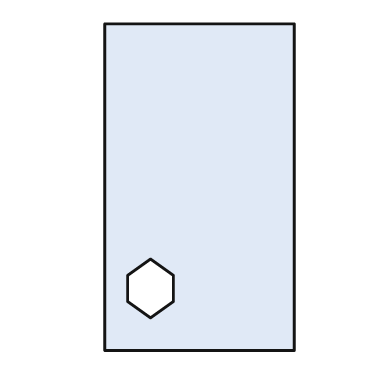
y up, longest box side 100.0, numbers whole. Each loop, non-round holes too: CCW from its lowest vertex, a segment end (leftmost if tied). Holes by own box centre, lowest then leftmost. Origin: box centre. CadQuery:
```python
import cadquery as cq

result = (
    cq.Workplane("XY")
    .moveTo(-29.0, -50.0)
    .lineTo(29.0, -50.0)
    .lineTo(29.0, 50.0)
    .lineTo(-29.0, 50.0)
    .close()
    .moveTo(-15.0, -40.0)
    .lineTo(-8.0, -35.0)
    .lineTo(-8.0, -27.0)
    .lineTo(-15.0, -22.0)
    .lineTo(-22.0, -27.0)
    .lineTo(-22.0, -35.0)
    .close()
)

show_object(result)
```